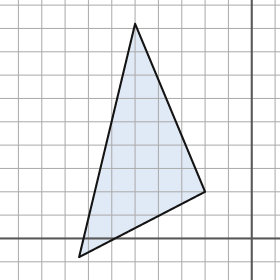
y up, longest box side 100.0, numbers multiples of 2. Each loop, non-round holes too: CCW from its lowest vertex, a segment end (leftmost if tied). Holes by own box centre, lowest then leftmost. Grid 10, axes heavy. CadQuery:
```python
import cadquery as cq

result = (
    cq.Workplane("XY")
    .moveTo(-74.0, -8.0)
    .lineTo(-20.0, 20.0)
    .lineTo(-50.0, 92.0)
    .close()
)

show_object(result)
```